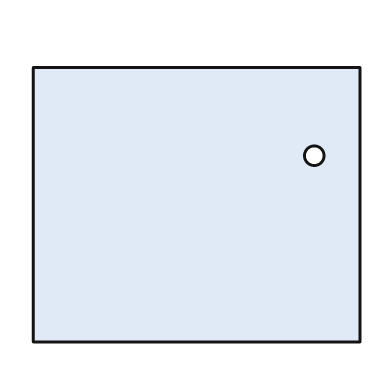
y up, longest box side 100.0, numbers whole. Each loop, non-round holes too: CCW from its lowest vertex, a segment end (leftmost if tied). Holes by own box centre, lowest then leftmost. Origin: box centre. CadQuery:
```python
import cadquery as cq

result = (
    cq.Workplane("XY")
    .moveTo(-50.0, -42.0)
    .lineTo(50.0, -42.0)
    .lineTo(50.0, 42.0)
    .lineTo(-50.0, 42.0)
    .close()
    .moveTo(36.0, 15.0)
    .circle(3.0)
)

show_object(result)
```